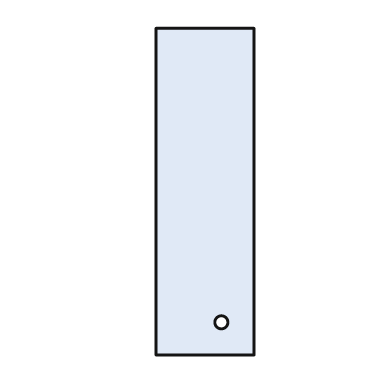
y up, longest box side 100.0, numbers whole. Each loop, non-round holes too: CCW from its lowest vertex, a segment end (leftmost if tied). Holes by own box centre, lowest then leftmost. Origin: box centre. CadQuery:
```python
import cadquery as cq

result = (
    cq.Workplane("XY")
    .moveTo(-15.0, -50.0)
    .lineTo(15.0, -50.0)
    .lineTo(15.0, 50.0)
    .lineTo(-15.0, 50.0)
    .close()
    .moveTo(5.0, -40.0)
    .circle(2.0)
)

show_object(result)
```